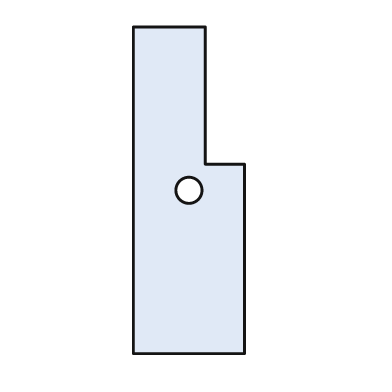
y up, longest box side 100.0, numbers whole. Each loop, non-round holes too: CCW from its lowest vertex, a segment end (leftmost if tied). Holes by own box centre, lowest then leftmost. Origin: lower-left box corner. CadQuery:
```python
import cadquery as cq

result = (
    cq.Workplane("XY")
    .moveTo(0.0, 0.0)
    .lineTo(34.0, 0.0)
    .lineTo(34.0, 58.0)
    .lineTo(22.0, 58.0)
    .lineTo(22.0, 100.0)
    .lineTo(0.0, 100.0)
    .close()
    .moveTo(17.0, 50.0)
    .circle(4.0)
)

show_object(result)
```